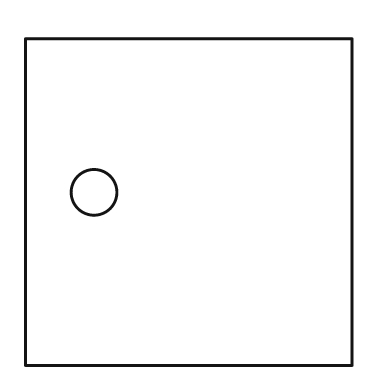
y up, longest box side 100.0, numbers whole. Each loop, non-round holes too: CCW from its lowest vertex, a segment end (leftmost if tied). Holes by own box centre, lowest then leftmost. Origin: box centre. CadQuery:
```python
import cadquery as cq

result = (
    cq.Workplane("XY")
    .moveTo(-50.0, -50.0)
    .lineTo(50.0, -50.0)
    .lineTo(50.0, 50.0)
    .lineTo(-50.0, 50.0)
    .close()
    .moveTo(-29.0, 3.0)
    .circle(7.0)
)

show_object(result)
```